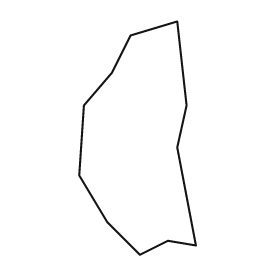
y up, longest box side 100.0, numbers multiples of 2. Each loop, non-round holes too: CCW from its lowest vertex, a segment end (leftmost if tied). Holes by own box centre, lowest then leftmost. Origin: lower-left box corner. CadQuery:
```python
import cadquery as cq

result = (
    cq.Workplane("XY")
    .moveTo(26.0, 0.0)
    .lineTo(38.0, 6.0)
    .lineTo(50.0, 4.0)
    .lineTo(42.0, 46.0)
    .lineTo(46.0, 64.0)
    .lineTo(42.0, 100.0)
    .lineTo(22.0, 94.0)
    .lineTo(14.0, 78.0)
    .lineTo(2.0, 64.0)
    .lineTo(0.0, 34.0)
    .lineTo(12.0, 14.0)
    .close()
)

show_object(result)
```